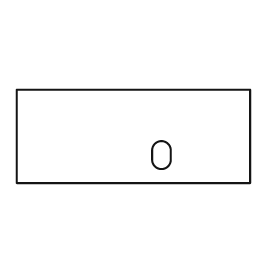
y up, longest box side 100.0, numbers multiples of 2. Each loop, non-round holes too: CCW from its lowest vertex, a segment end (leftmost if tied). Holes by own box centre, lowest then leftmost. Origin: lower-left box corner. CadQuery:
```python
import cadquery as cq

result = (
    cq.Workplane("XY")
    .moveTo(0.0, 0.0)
    .lineTo(100.0, 0.0)
    .lineTo(100.0, 40.0)
    .lineTo(0.0, 40.0)
    .close()
    .moveTo(58.0, 10.0)
    .threePointArc((62.0, 6.0), (66.0, 10.0))
    .lineTo(66.0, 14.0)
    .threePointArc((62.0, 18.0), (58.0, 14.0))
    .close()
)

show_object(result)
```